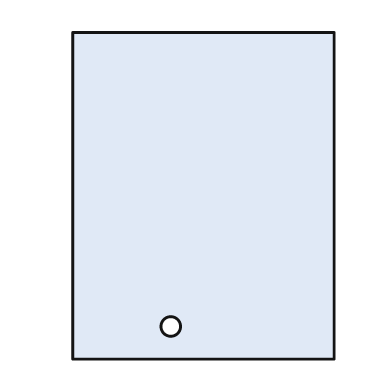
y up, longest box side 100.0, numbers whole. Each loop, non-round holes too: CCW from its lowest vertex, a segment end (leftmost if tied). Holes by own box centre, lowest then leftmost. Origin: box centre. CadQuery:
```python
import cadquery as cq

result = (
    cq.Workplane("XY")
    .moveTo(-40.0, -50.0)
    .lineTo(40.0, -50.0)
    .lineTo(40.0, 50.0)
    .lineTo(-40.0, 50.0)
    .close()
    .moveTo(-10.0, -40.0)
    .circle(3.0)
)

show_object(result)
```